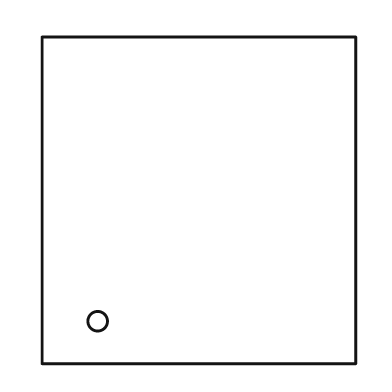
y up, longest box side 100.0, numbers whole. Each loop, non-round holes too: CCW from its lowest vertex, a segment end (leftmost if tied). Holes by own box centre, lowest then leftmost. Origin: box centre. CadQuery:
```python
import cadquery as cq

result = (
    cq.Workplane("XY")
    .moveTo(-48.0, -50.0)
    .lineTo(48.0, -50.0)
    .lineTo(48.0, 50.0)
    .lineTo(-48.0, 50.0)
    .close()
    .moveTo(-31.0, -37.0)
    .circle(3.0)
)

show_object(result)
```